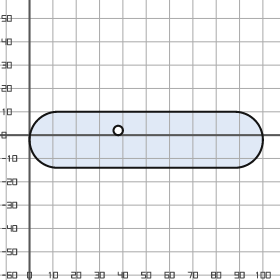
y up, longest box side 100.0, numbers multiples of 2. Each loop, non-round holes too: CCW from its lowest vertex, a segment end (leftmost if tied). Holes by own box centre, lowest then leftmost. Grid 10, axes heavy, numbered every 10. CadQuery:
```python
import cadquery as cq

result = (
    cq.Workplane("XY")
    .moveTo(12.0, -14.0)
    .lineTo(88.0, -14.0)
    .threePointArc((100.0, -2.0), (88.0, 10.0))
    .lineTo(12.0, 10.0)
    .threePointArc((0.0, -2.0), (12.0, -14.0))
    .close()
    .moveTo(38.0, 2.0)
    .circle(2.0)
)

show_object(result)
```